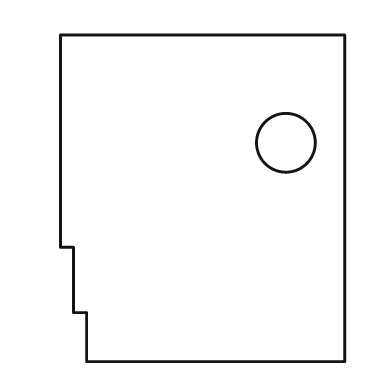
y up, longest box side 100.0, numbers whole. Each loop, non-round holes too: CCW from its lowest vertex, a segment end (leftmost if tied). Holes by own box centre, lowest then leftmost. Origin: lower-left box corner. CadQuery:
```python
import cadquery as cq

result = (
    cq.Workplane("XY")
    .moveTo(8.0, 0.0)
    .lineTo(87.0, 0.0)
    .lineTo(87.0, 100.0)
    .lineTo(0.0, 100.0)
    .lineTo(0.0, 35.0)
    .lineTo(4.0, 35.0)
    .lineTo(4.0, 15.0)
    .lineTo(8.0, 15.0)
    .close()
    .moveTo(69.0, 67.0)
    .circle(9.0)
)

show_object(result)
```